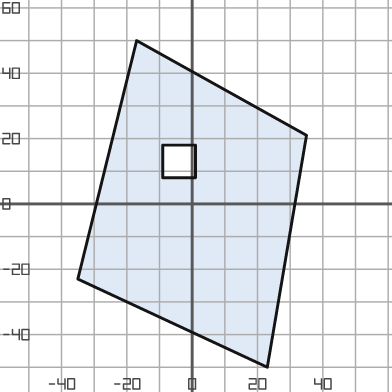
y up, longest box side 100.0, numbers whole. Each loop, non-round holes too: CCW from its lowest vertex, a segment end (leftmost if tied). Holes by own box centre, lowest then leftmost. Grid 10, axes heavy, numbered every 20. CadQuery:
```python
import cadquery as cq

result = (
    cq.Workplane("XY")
    .moveTo(23.0, -50.0)
    .lineTo(35.0, 21.0)
    .lineTo(-17.0, 50.0)
    .lineTo(-35.0, -23.0)
    .close()
    .moveTo(-9.0, 8.0)
    .lineTo(1.0, 8.0)
    .lineTo(1.0, 18.0)
    .lineTo(-9.0, 18.0)
    .close()
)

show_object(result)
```